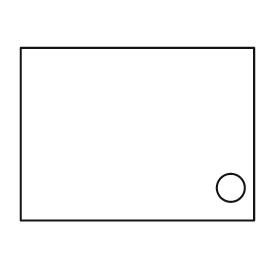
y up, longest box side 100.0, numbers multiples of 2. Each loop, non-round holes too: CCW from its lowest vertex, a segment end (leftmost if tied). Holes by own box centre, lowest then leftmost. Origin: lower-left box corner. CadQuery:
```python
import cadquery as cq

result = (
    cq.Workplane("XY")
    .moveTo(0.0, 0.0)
    .lineTo(100.0, 0.0)
    .lineTo(100.0, 74.0)
    .lineTo(0.0, 74.0)
    .close()
    .moveTo(90.0, 14.0)
    .circle(6.0)
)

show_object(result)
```